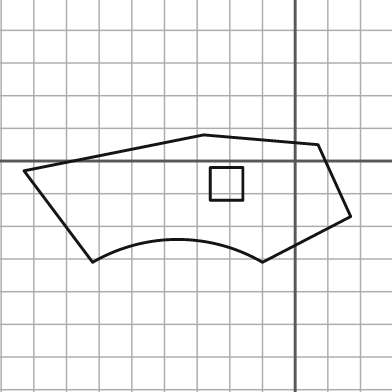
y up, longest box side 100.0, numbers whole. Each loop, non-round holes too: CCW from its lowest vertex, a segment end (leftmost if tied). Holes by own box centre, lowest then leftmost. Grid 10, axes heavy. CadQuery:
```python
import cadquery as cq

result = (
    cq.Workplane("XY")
    .moveTo(-62.0, -31.0)
    .threePointArc((-36.0, -24.0), (-10.0, -31.0))
    .lineTo(17.0, -17.0)
    .lineTo(7.0, 5.0)
    .lineTo(-28.0, 8.0)
    .lineTo(-83.0, -3.0)
    .close()
    .moveTo(-26.0, -12.0)
    .lineTo(-16.0, -12.0)
    .lineTo(-16.0, -2.0)
    .lineTo(-26.0, -2.0)
    .close()
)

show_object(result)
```